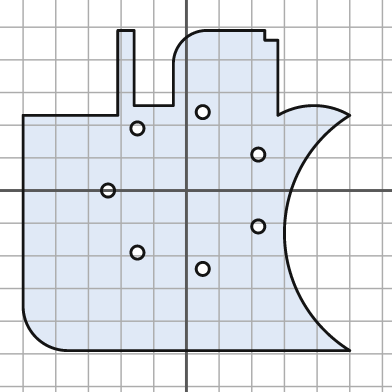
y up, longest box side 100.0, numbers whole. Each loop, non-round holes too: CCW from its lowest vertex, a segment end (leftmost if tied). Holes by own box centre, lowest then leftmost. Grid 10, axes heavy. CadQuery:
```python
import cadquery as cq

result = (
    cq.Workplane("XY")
    .moveTo(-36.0, -49.0)
    .lineTo(50.0, -49.0)
    .threePointArc((30.0, -13.0), (50.0, 23.0))
    .threePointArc((39.0, 26.0), (28.0, 23.0))
    .lineTo(28.0, 46.0)
    .lineTo(24.0, 46.0)
    .lineTo(24.0, 49.0)
    .lineTo(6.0, 49.0)
    .threePointArc((-1.0, 46.0), (-4.0, 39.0))
    .lineTo(-4.0, 26.0)
    .lineTo(-16.0, 26.0)
    .lineTo(-16.0, 49.0)
    .lineTo(-21.0, 49.0)
    .lineTo(-21.0, 23.0)
    .lineTo(-50.0, 23.0)
    .lineTo(-50.0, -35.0)
    .threePointArc((-46.0, -45.0), (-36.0, -49.0))
    .close()
    .moveTo(5.0, -24.0)
    .circle(2.0)
    .moveTo(-15.0, -19.0)
    .circle(2.0)
    .moveTo(22.0, -11.0)
    .circle(2.0)
    .moveTo(-24.0, 0.0)
    .circle(2.0)
    .moveTo(22.0, 11.0)
    .circle(2.0)
    .moveTo(-15.0, 19.0)
    .circle(2.0)
    .moveTo(5.0, 24.0)
    .circle(2.0)
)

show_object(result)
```